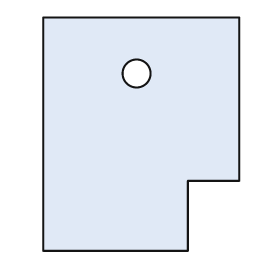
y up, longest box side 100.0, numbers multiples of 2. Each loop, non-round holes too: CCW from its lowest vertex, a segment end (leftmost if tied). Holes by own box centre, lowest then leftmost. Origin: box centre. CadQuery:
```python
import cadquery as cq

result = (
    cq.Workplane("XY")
    .moveTo(-42.0, -50.0)
    .lineTo(20.0, -50.0)
    .lineTo(20.0, -20.0)
    .lineTo(42.0, -20.0)
    .lineTo(42.0, 50.0)
    .lineTo(-42.0, 50.0)
    .close()
    .moveTo(-2.0, 26.0)
    .circle(6.0)
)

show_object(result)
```